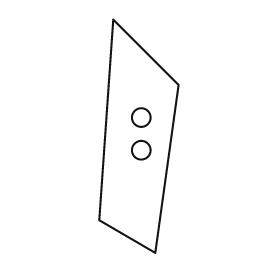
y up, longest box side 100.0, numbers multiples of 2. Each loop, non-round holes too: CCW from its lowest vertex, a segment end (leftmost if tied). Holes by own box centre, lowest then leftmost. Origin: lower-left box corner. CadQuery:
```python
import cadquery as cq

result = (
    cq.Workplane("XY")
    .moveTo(24.0, 0.0)
    .lineTo(34.0, 72.0)
    .lineTo(6.0, 100.0)
    .lineTo(0.0, 14.0)
    .close()
    .moveTo(18.0, 44.0)
    .circle(4.0)
    .moveTo(18.0, 58.0)
    .circle(4.0)
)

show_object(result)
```